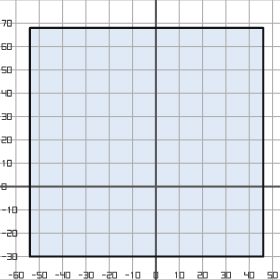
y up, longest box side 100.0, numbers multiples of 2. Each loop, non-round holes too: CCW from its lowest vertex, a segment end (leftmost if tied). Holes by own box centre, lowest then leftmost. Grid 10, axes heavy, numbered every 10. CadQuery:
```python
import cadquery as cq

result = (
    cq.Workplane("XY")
    .moveTo(-54.0, -30.0)
    .lineTo(46.0, -30.0)
    .lineTo(46.0, 68.0)
    .lineTo(-54.0, 68.0)
    .close()
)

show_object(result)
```